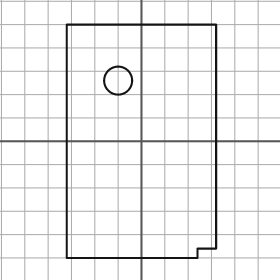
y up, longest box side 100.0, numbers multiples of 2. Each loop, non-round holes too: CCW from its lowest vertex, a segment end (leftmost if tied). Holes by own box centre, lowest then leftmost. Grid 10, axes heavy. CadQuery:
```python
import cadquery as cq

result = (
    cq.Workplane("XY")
    .moveTo(-32.0, -50.0)
    .lineTo(24.0, -50.0)
    .lineTo(24.0, -46.0)
    .lineTo(32.0, -46.0)
    .lineTo(32.0, 50.0)
    .lineTo(-32.0, 50.0)
    .close()
    .moveTo(-10.0, 26.0)
    .circle(6.0)
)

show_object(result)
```